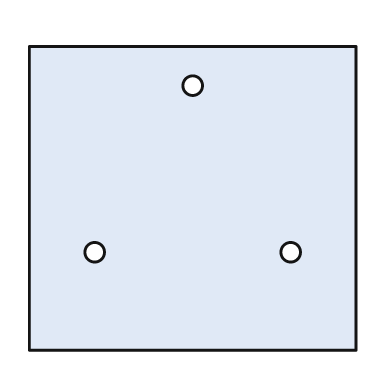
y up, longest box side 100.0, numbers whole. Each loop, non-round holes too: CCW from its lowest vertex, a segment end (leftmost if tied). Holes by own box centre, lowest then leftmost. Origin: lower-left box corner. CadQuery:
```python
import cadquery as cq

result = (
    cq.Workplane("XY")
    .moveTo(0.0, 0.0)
    .lineTo(100.0, 0.0)
    .lineTo(100.0, 93.0)
    .lineTo(0.0, 93.0)
    .close()
    .moveTo(20.0, 30.0)
    .circle(3.0)
    .moveTo(80.0, 30.0)
    .circle(3.0)
    .moveTo(50.0, 81.0)
    .circle(3.0)
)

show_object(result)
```